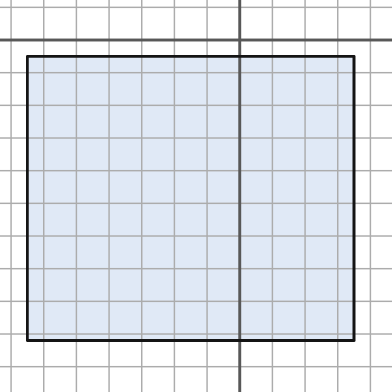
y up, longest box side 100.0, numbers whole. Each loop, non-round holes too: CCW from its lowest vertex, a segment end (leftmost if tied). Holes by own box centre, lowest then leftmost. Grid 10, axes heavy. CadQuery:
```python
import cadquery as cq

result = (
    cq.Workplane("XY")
    .moveTo(-65.0, -92.0)
    .lineTo(35.0, -92.0)
    .lineTo(35.0, -5.0)
    .lineTo(-65.0, -5.0)
    .close()
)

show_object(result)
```